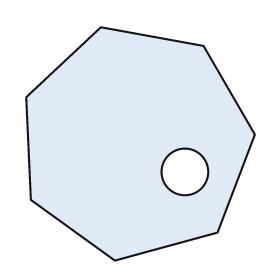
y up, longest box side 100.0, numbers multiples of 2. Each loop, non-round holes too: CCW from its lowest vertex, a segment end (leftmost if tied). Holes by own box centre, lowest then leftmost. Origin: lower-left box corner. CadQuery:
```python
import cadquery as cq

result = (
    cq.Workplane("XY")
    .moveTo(38.0, 0.0)
    .lineTo(82.0, 12.0)
    .lineTo(98.0, 54.0)
    .lineTo(76.0, 92.0)
    .lineTo(32.0, 100.0)
    .lineTo(0.0, 70.0)
    .lineTo(2.0, 26.0)
    .close()
    .moveTo(68.0, 38.0)
    .circle(10.0)
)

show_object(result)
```